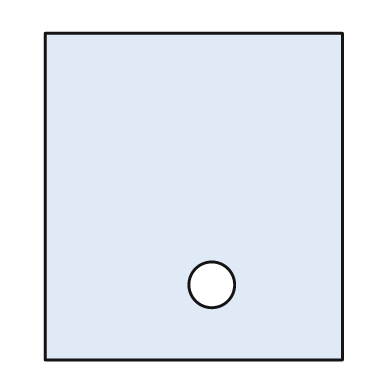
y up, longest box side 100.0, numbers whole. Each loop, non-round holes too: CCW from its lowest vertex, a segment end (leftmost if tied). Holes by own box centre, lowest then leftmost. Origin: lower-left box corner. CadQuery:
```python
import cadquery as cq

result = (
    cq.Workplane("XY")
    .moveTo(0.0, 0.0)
    .lineTo(91.0, 0.0)
    .lineTo(91.0, 100.0)
    .lineTo(0.0, 100.0)
    .close()
    .moveTo(51.0, 23.0)
    .circle(7.0)
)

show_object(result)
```